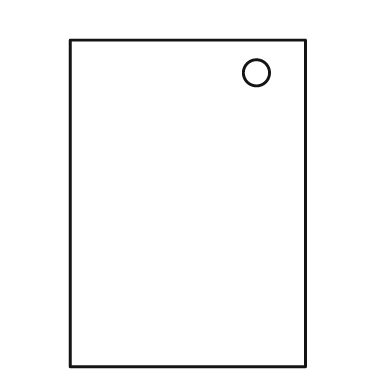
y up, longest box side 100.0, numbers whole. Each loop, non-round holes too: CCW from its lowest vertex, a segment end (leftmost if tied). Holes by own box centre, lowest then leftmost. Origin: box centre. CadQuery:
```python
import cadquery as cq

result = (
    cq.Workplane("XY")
    .moveTo(-36.0, -50.0)
    .lineTo(36.0, -50.0)
    .lineTo(36.0, 50.0)
    .lineTo(-36.0, 50.0)
    .close()
    .moveTo(21.0, 40.0)
    .circle(4.0)
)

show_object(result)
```